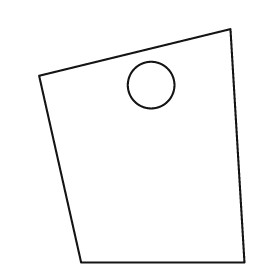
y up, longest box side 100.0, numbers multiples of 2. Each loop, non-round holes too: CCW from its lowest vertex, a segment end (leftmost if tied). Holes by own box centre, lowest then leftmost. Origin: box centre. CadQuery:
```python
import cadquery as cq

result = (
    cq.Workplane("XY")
    .moveTo(-26.0, -50.0)
    .lineTo(44.0, -50.0)
    .lineTo(38.0, 50.0)
    .lineTo(-44.0, 30.0)
    .close()
    .moveTo(4.0, 26.0)
    .circle(10.0)
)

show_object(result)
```